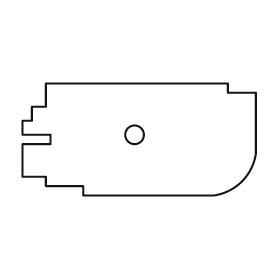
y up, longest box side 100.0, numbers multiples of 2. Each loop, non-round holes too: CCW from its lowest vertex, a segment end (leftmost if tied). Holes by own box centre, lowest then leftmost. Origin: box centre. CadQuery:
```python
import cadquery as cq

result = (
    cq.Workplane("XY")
    .moveTo(-24.0, -24.0)
    .lineTo(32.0, -24.0)
    .threePointArc((44.0, -18.0), (50.0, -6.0))
    .lineTo(50.0, 20.0)
    .lineTo(38.0, 20.0)
    .lineTo(38.0, 24.0)
    .lineTo(-40.0, 24.0)
    .lineTo(-40.0, 14.0)
    .lineTo(-46.0, 14.0)
    .lineTo(-46.0, 8.0)
    .lineTo(-50.0, 8.0)
    .lineTo(-50.0, 2.0)
    .lineTo(-38.0, 2.0)
    .lineTo(-38.0, -2.0)
    .lineTo(-50.0, -2.0)
    .lineTo(-50.0, -16.0)
    .lineTo(-40.0, -16.0)
    .lineTo(-40.0, -20.0)
    .lineTo(-24.0, -20.0)
    .close()
    .moveTo(-2.0, 2.0)
    .circle(4.0)
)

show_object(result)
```